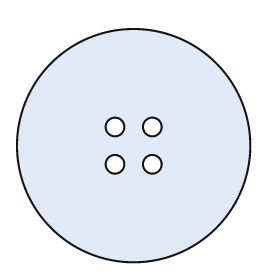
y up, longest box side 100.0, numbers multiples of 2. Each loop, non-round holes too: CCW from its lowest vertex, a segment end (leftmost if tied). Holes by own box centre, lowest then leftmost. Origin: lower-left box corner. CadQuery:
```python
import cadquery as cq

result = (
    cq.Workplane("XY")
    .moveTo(50.0, 50.0)
    .circle(50.0)
    .moveTo(42.0, 42.0)
    .circle(4.0)
    .moveTo(58.0, 42.0)
    .circle(4.0)
    .moveTo(42.0, 58.0)
    .circle(4.0)
    .moveTo(58.0, 58.0)
    .circle(4.0)
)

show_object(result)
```